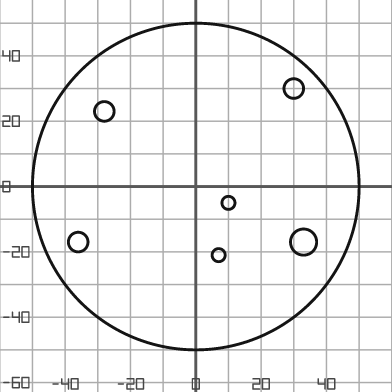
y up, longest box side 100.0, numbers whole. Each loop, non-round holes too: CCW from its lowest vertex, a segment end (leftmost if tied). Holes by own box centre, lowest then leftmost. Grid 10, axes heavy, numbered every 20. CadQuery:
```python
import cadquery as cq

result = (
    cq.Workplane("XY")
    .moveTo(0.0, 0.0)
    .circle(50.0)
    .moveTo(7.0, -21.0)
    .circle(2.0)
    .moveTo(-36.0, -17.0)
    .circle(3.0)
    .moveTo(33.0, -17.0)
    .circle(4.0)
    .moveTo(10.0, -5.0)
    .circle(2.0)
    .moveTo(-28.0, 23.0)
    .circle(3.0)
    .moveTo(30.0, 30.0)
    .circle(3.0)
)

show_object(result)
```